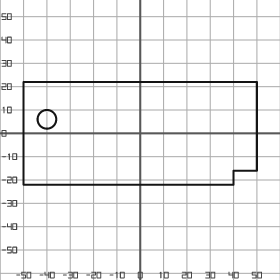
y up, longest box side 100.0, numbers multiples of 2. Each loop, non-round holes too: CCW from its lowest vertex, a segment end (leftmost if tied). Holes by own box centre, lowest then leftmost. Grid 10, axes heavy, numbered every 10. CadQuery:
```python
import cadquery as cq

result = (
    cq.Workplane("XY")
    .moveTo(-50.0, -22.0)
    .lineTo(40.0, -22.0)
    .lineTo(40.0, -16.0)
    .lineTo(50.0, -16.0)
    .lineTo(50.0, 22.0)
    .lineTo(-50.0, 22.0)
    .close()
    .moveTo(-40.0, 6.0)
    .circle(4.0)
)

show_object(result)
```